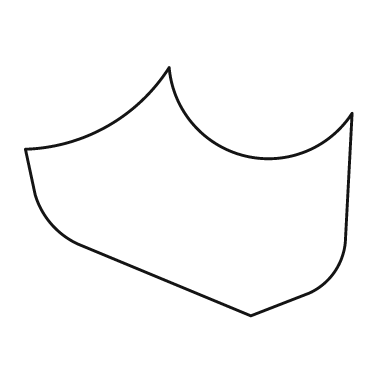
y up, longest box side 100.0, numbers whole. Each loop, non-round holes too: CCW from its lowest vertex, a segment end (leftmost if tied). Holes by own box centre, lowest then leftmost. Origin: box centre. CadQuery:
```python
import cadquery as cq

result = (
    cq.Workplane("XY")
    .moveTo(19.0, -38.0)
    .lineTo(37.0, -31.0)
    .threePointArc((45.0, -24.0), (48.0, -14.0))
    .lineTo(50.0, 24.0)
    .threePointArc((17.0, 11.0), (-6.0, 38.0))
    .threePointArc((-25.0, 20.0), (-50.0, 13.0))
    .lineTo(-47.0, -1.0)
    .threePointArc((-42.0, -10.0), (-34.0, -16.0))
    .close()
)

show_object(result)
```